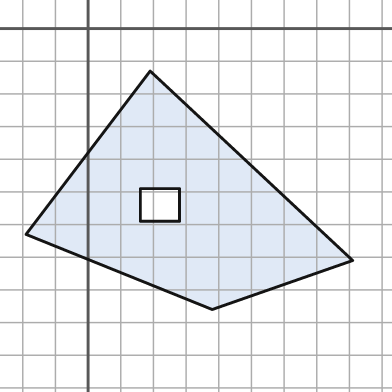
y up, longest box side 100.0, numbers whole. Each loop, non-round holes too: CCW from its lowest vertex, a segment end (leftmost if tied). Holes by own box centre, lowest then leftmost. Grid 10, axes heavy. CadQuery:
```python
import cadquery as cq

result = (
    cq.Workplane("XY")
    .moveTo(38.0, -86.0)
    .lineTo(81.0, -71.0)
    .lineTo(19.0, -13.0)
    .lineTo(-19.0, -63.0)
    .close()
    .moveTo(16.0, -59.0)
    .lineTo(28.0, -59.0)
    .lineTo(28.0, -49.0)
    .lineTo(16.0, -49.0)
    .close()
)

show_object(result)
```